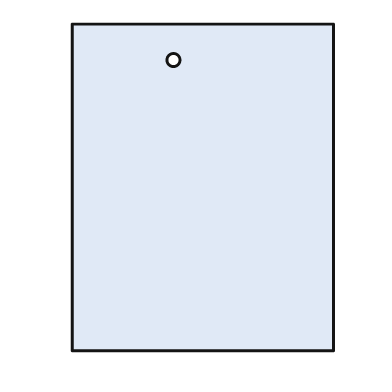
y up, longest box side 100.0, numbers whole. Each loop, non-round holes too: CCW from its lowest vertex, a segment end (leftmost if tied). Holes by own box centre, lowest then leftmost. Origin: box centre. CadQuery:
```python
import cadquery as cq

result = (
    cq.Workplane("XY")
    .moveTo(-40.0, -50.0)
    .lineTo(40.0, -50.0)
    .lineTo(40.0, 50.0)
    .lineTo(-40.0, 50.0)
    .close()
    .moveTo(-9.0, 39.0)
    .circle(2.0)
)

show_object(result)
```